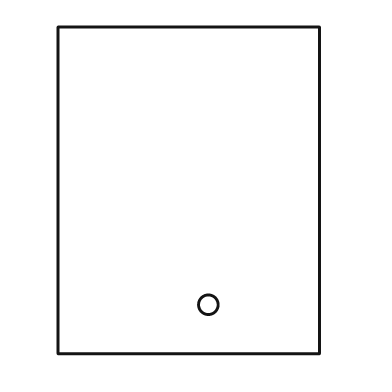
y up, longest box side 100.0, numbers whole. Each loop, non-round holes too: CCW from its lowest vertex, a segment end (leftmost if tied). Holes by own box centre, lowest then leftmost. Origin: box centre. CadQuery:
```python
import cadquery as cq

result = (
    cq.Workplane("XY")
    .moveTo(-40.0, -50.0)
    .lineTo(40.0, -50.0)
    .lineTo(40.0, 50.0)
    .lineTo(-40.0, 50.0)
    .close()
    .moveTo(6.0, -35.0)
    .circle(3.0)
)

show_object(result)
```